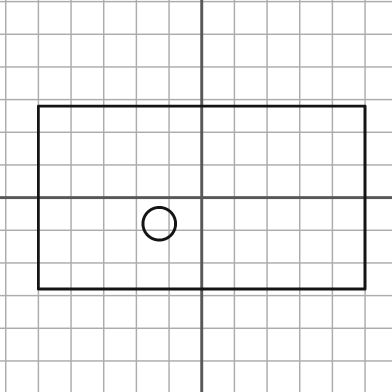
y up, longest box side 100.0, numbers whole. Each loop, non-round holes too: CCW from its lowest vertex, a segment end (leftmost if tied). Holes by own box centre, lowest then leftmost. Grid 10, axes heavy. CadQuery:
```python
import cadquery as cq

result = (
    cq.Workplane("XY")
    .moveTo(-50.0, -28.0)
    .lineTo(50.0, -28.0)
    .lineTo(50.0, 28.0)
    .lineTo(-50.0, 28.0)
    .close()
    .moveTo(-13.0, -8.0)
    .circle(5.0)
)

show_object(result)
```